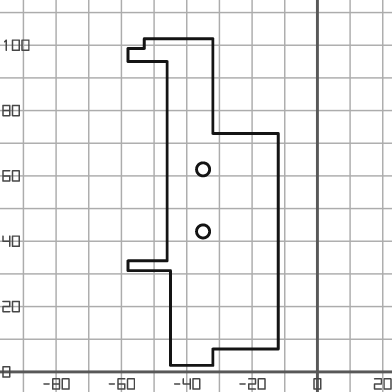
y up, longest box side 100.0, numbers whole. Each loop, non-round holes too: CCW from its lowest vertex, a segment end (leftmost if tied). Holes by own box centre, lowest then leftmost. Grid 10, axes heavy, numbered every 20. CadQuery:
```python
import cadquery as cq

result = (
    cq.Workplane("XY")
    .moveTo(-45.0, 2.0)
    .lineTo(-32.0, 2.0)
    .lineTo(-32.0, 7.0)
    .lineTo(-12.0, 7.0)
    .lineTo(-12.0, 73.0)
    .lineTo(-32.0, 73.0)
    .lineTo(-32.0, 102.0)
    .lineTo(-53.0, 102.0)
    .lineTo(-53.0, 99.0)
    .lineTo(-58.0, 99.0)
    .lineTo(-58.0, 95.0)
    .lineTo(-46.0, 95.0)
    .lineTo(-46.0, 34.0)
    .lineTo(-58.0, 34.0)
    .lineTo(-58.0, 31.0)
    .lineTo(-45.0, 31.0)
    .close()
    .moveTo(-35.0, 43.0)
    .circle(2.0)
    .moveTo(-35.0, 62.0)
    .circle(2.0)
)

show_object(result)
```